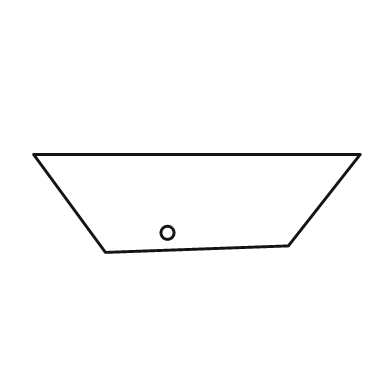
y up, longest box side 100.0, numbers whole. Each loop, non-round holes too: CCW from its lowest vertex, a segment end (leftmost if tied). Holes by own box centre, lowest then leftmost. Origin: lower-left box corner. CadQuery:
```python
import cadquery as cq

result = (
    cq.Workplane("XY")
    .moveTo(22.0, 0.0)
    .lineTo(78.0, 2.0)
    .lineTo(100.0, 30.0)
    .lineTo(0.0, 30.0)
    .close()
    .moveTo(41.0, 6.0)
    .circle(2.0)
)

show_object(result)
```